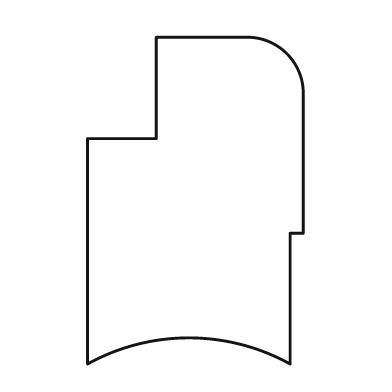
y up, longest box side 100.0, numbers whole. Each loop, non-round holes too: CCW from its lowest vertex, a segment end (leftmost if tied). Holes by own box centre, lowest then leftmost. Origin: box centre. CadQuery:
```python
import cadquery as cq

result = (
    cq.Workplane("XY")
    .moveTo(-33.0, -50.0)
    .threePointArc((-2.0, -42.0), (29.0, -50.0))
    .lineTo(29.0, -10.0)
    .lineTo(33.0, -10.0)
    .lineTo(33.0, 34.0)
    .threePointArc((28.0, 45.0), (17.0, 50.0))
    .lineTo(-12.0, 50.0)
    .lineTo(-12.0, 19.0)
    .lineTo(-33.0, 19.0)
    .close()
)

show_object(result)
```